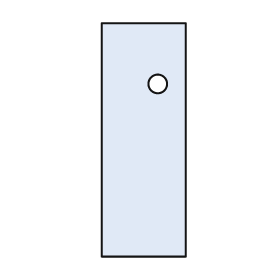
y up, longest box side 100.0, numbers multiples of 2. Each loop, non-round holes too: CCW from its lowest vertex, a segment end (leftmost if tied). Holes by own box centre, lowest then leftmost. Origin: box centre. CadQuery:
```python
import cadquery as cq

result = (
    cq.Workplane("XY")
    .moveTo(-18.0, -50.0)
    .lineTo(18.0, -50.0)
    .lineTo(18.0, 50.0)
    .lineTo(-18.0, 50.0)
    .close()
    .moveTo(6.0, 24.0)
    .circle(4.0)
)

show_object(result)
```